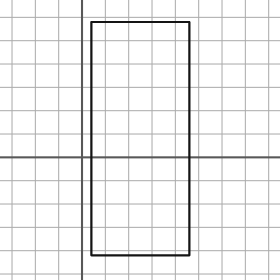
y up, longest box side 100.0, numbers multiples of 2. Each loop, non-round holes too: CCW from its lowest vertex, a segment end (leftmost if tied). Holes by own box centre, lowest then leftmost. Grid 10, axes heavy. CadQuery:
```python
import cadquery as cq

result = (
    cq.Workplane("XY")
    .moveTo(4.0, -42.0)
    .lineTo(46.0, -42.0)
    .lineTo(46.0, 58.0)
    .lineTo(4.0, 58.0)
    .close()
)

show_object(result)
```